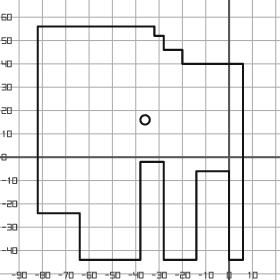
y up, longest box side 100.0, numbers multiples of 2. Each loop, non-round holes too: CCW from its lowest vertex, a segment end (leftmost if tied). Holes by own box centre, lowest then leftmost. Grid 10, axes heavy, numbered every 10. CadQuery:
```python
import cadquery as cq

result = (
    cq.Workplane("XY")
    .moveTo(-64.0, -44.0)
    .lineTo(-38.0, -44.0)
    .lineTo(-38.0, -2.0)
    .lineTo(-28.0, -2.0)
    .lineTo(-28.0, -44.0)
    .lineTo(-14.0, -44.0)
    .lineTo(-14.0, -6.0)
    .lineTo(0.0, -6.0)
    .lineTo(0.0, -44.0)
    .lineTo(6.0, -44.0)
    .lineTo(6.0, 40.0)
    .lineTo(-20.0, 40.0)
    .lineTo(-20.0, 46.0)
    .lineTo(-28.0, 46.0)
    .lineTo(-28.0, 52.0)
    .lineTo(-32.0, 52.0)
    .lineTo(-32.0, 56.0)
    .lineTo(-82.0, 56.0)
    .lineTo(-82.0, -24.0)
    .lineTo(-64.0, -24.0)
    .close()
    .moveTo(-36.0, 16.0)
    .circle(2.0)
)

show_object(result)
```